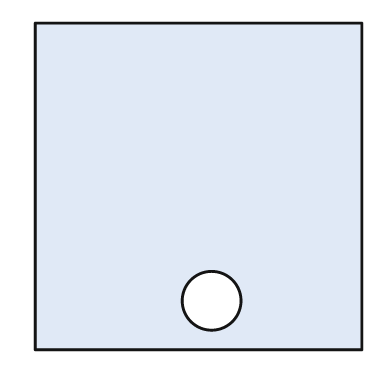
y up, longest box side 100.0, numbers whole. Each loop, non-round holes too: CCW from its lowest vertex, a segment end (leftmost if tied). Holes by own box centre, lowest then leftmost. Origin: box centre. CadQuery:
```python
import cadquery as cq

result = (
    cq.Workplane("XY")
    .moveTo(-50.0, -50.0)
    .lineTo(50.0, -50.0)
    .lineTo(50.0, 50.0)
    .lineTo(-50.0, 50.0)
    .close()
    .moveTo(4.0, -35.0)
    .circle(9.0)
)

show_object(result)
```